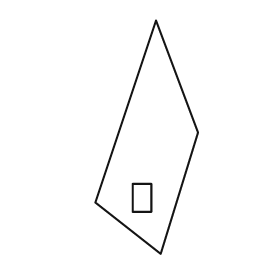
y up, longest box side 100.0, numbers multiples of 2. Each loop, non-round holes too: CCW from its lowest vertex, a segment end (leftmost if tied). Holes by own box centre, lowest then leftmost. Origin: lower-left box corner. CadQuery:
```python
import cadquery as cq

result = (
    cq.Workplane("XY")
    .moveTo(28.0, 0.0)
    .lineTo(44.0, 52.0)
    .lineTo(26.0, 100.0)
    .lineTo(0.0, 22.0)
    .close()
    .moveTo(16.0, 18.0)
    .lineTo(24.0, 18.0)
    .lineTo(24.0, 30.0)
    .lineTo(16.0, 30.0)
    .close()
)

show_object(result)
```